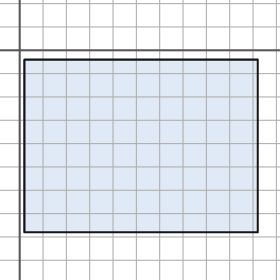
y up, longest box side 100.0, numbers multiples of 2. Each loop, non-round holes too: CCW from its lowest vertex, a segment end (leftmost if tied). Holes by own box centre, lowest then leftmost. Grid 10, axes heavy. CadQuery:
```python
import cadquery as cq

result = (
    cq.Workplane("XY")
    .moveTo(2.0, -78.0)
    .lineTo(102.0, -78.0)
    .lineTo(102.0, -4.0)
    .lineTo(2.0, -4.0)
    .close()
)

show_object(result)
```